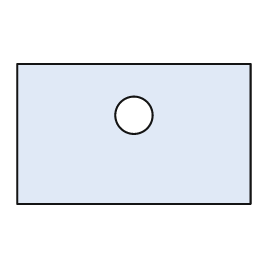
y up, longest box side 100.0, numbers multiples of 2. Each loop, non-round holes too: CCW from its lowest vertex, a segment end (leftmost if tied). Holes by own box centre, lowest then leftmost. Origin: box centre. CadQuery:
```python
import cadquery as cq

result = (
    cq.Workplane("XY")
    .moveTo(-50.0, -30.0)
    .lineTo(50.0, -30.0)
    .lineTo(50.0, 30.0)
    .lineTo(-50.0, 30.0)
    .close()
    .moveTo(0.0, 8.0)
    .circle(8.0)
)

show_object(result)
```